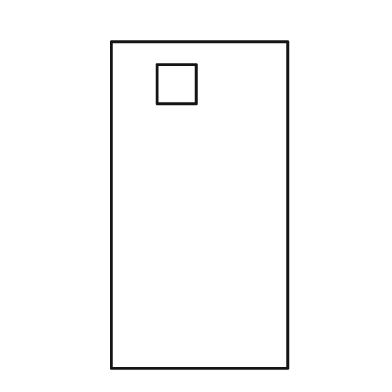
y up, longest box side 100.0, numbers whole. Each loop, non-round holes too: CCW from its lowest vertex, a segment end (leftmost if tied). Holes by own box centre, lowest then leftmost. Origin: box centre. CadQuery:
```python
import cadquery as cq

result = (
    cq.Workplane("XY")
    .moveTo(-27.0, -50.0)
    .lineTo(27.0, -50.0)
    .lineTo(27.0, 50.0)
    .lineTo(-27.0, 50.0)
    .close()
    .moveTo(-13.0, 31.0)
    .lineTo(-1.0, 31.0)
    .lineTo(-1.0, 43.0)
    .lineTo(-13.0, 43.0)
    .close()
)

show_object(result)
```